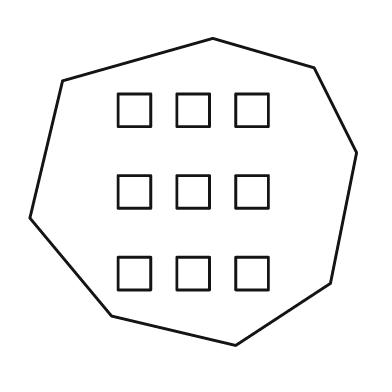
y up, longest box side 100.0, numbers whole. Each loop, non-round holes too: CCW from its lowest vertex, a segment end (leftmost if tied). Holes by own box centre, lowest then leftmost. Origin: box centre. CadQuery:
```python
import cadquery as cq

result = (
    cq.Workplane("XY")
    .moveTo(13.0, -47.0)
    .lineTo(42.0, -28.0)
    .lineTo(50.0, 12.0)
    .lineTo(37.0, 38.0)
    .lineTo(6.0, 47.0)
    .lineTo(-40.0, 34.0)
    .lineTo(-50.0, -8.0)
    .lineTo(-25.0, -38.0)
    .close()
    .moveTo(-23.0, -30.0)
    .lineTo(-13.0, -30.0)
    .lineTo(-13.0, -20.0)
    .lineTo(-23.0, -20.0)
    .close()
    .moveTo(-5.0, -30.0)
    .lineTo(5.0, -30.0)
    .lineTo(5.0, -20.0)
    .lineTo(-5.0, -20.0)
    .close()
    .moveTo(13.0, -30.0)
    .lineTo(23.0, -30.0)
    .lineTo(23.0, -20.0)
    .lineTo(13.0, -20.0)
    .close()
    .moveTo(-23.0, -5.0)
    .lineTo(-13.0, -5.0)
    .lineTo(-13.0, 5.0)
    .lineTo(-23.0, 5.0)
    .close()
    .moveTo(-5.0, -5.0)
    .lineTo(5.0, -5.0)
    .lineTo(5.0, 5.0)
    .lineTo(-5.0, 5.0)
    .close()
    .moveTo(13.0, -5.0)
    .lineTo(23.0, -5.0)
    .lineTo(23.0, 5.0)
    .lineTo(13.0, 5.0)
    .close()
    .moveTo(-23.0, 20.0)
    .lineTo(-13.0, 20.0)
    .lineTo(-13.0, 30.0)
    .lineTo(-23.0, 30.0)
    .close()
    .moveTo(-5.0, 20.0)
    .lineTo(5.0, 20.0)
    .lineTo(5.0, 30.0)
    .lineTo(-5.0, 30.0)
    .close()
    .moveTo(13.0, 20.0)
    .lineTo(23.0, 20.0)
    .lineTo(23.0, 30.0)
    .lineTo(13.0, 30.0)
    .close()
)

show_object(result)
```